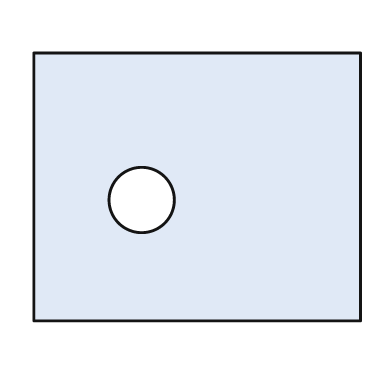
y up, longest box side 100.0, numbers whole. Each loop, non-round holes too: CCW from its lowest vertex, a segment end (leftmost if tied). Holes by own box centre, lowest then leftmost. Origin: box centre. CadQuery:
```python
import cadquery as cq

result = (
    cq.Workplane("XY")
    .moveTo(-50.0, -41.0)
    .lineTo(50.0, -41.0)
    .lineTo(50.0, 41.0)
    .lineTo(-50.0, 41.0)
    .close()
    .moveTo(-17.0, -4.0)
    .circle(10.0)
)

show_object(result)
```